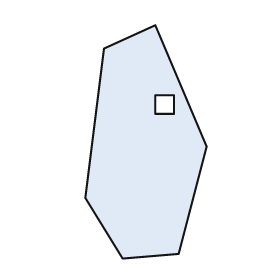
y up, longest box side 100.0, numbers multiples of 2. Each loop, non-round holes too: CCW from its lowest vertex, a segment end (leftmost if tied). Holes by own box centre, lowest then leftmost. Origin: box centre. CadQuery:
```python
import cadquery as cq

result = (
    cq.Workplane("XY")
    .moveTo(-10.0, -50.0)
    .lineTo(14.0, -48.0)
    .lineTo(26.0, -2.0)
    .lineTo(4.0, 50.0)
    .lineTo(-18.0, 40.0)
    .lineTo(-26.0, -24.0)
    .close()
    .moveTo(4.0, 12.0)
    .lineTo(12.0, 12.0)
    .lineTo(12.0, 20.0)
    .lineTo(4.0, 20.0)
    .close()
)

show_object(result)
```